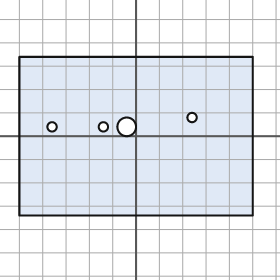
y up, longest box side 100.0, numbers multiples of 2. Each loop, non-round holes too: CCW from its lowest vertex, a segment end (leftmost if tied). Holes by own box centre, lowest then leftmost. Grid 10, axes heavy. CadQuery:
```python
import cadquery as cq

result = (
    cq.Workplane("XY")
    .moveTo(-50.0, -34.0)
    .lineTo(50.0, -34.0)
    .lineTo(50.0, 34.0)
    .lineTo(-50.0, 34.0)
    .close()
    .moveTo(-36.0, 4.0)
    .circle(2.0)
    .moveTo(-14.0, 4.0)
    .circle(2.0)
    .moveTo(-4.0, 4.0)
    .circle(4.0)
    .moveTo(24.0, 8.0)
    .circle(2.0)
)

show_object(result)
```